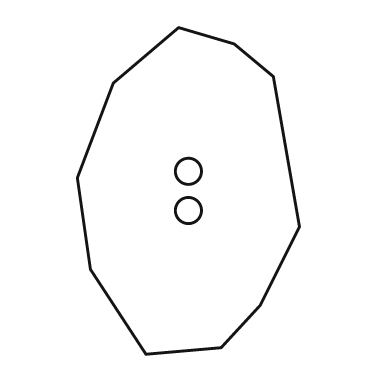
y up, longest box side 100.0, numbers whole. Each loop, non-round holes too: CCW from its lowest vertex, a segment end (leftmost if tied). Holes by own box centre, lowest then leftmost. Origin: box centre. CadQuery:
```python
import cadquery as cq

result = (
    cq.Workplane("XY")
    .moveTo(-13.0, -50.0)
    .lineTo(10.0, -48.0)
    .lineTo(22.0, -35.0)
    .lineTo(34.0, -11.0)
    .lineTo(26.0, 35.0)
    .lineTo(14.0, 45.0)
    .lineTo(-3.0, 50.0)
    .lineTo(-23.0, 33.0)
    .lineTo(-34.0, 4.0)
    .lineTo(-30.0, -24.0)
    .close()
    .moveTo(0.0, -6.0)
    .circle(4.0)
    .moveTo(0.0, 6.0)
    .circle(4.0)
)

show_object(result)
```